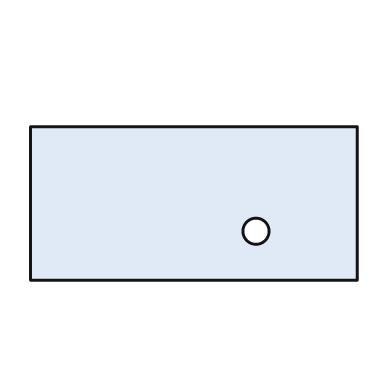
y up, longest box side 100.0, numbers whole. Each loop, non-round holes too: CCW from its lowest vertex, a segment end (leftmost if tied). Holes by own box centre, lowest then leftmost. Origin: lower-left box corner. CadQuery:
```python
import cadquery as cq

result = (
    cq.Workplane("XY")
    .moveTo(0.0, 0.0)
    .lineTo(100.0, 0.0)
    .lineTo(100.0, 47.0)
    .lineTo(0.0, 47.0)
    .close()
    .moveTo(69.0, 15.0)
    .circle(4.0)
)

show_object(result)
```